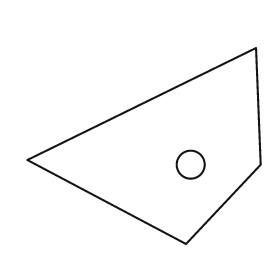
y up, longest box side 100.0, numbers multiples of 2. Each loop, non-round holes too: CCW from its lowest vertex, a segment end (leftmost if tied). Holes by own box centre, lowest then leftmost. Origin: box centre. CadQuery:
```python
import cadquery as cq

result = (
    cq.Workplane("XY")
    .moveTo(18.0, -42.0)
    .lineTo(50.0, -8.0)
    .lineTo(48.0, 42.0)
    .lineTo(-50.0, -6.0)
    .close()
    .moveTo(20.0, -8.0)
    .circle(6.0)
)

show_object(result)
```